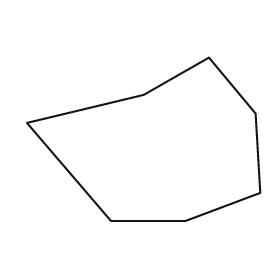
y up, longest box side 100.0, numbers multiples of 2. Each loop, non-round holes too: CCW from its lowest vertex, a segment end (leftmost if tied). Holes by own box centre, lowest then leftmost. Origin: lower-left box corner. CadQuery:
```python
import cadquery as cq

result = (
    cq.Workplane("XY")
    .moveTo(36.0, 0.0)
    .lineTo(68.0, 0.0)
    .lineTo(100.0, 12.0)
    .lineTo(98.0, 46.0)
    .lineTo(78.0, 70.0)
    .lineTo(50.0, 54.0)
    .lineTo(0.0, 42.0)
    .close()
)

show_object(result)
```